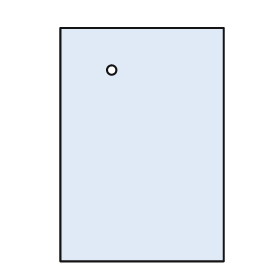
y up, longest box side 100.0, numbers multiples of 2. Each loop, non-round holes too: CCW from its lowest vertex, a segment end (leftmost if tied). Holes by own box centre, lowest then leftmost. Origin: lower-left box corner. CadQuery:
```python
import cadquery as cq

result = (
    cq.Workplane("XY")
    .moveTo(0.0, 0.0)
    .lineTo(70.0, 0.0)
    .lineTo(70.0, 100.0)
    .lineTo(0.0, 100.0)
    .close()
    .moveTo(22.0, 82.0)
    .circle(2.0)
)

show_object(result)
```